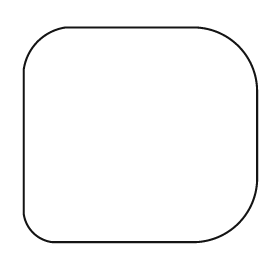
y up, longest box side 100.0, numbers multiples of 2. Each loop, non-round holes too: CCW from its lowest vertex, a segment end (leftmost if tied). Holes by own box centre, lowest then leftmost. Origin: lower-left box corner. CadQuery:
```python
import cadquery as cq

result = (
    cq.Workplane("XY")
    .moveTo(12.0, 0.0)
    .lineTo(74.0, 0.0)
    .threePointArc((92.0, 8.0), (100.0, 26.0))
    .lineTo(100.0, 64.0)
    .threePointArc((92.0, 84.0), (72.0, 92.0))
    .lineTo(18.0, 92.0)
    .threePointArc((6.0, 86.0), (0.0, 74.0))
    .lineTo(0.0, 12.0)
    .threePointArc((4.0, 4.0), (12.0, 0.0))
    .close()
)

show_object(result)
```